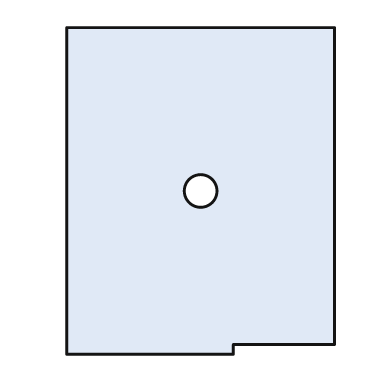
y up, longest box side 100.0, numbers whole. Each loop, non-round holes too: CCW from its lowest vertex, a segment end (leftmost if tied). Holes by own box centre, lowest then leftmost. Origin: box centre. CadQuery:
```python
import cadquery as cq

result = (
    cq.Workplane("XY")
    .moveTo(-41.0, -50.0)
    .lineTo(10.0, -50.0)
    .lineTo(10.0, -47.0)
    .lineTo(41.0, -47.0)
    .lineTo(41.0, 50.0)
    .lineTo(-41.0, 50.0)
    .close()
    .moveTo(0.0, 0.0)
    .circle(5.0)
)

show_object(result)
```